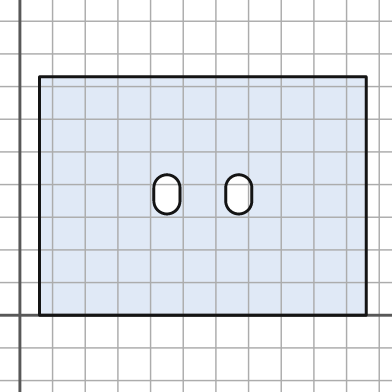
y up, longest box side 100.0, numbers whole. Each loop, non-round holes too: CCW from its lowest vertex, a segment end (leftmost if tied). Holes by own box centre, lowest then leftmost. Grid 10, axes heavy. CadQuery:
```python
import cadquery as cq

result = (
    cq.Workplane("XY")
    .moveTo(6.0, 0.0)
    .lineTo(106.0, 0.0)
    .lineTo(106.0, 73.0)
    .lineTo(6.0, 73.0)
    .close()
    .moveTo(41.0, 35.0)
    .threePointArc((45.0, 31.0), (49.0, 35.0))
    .lineTo(49.0, 39.0)
    .threePointArc((45.0, 43.0), (41.0, 39.0))
    .close()
    .moveTo(63.0, 35.0)
    .threePointArc((67.0, 31.0), (71.0, 35.0))
    .lineTo(71.0, 39.0)
    .threePointArc((67.0, 43.0), (63.0, 39.0))
    .close()
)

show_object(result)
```